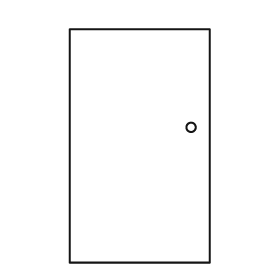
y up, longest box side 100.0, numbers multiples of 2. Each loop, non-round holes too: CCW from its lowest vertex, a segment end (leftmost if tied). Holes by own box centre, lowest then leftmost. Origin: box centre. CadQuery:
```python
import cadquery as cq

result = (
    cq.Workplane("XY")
    .moveTo(-30.0, -50.0)
    .lineTo(30.0, -50.0)
    .lineTo(30.0, 50.0)
    .lineTo(-30.0, 50.0)
    .close()
    .moveTo(22.0, 8.0)
    .circle(2.0)
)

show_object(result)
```